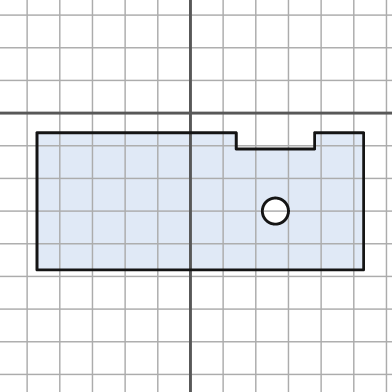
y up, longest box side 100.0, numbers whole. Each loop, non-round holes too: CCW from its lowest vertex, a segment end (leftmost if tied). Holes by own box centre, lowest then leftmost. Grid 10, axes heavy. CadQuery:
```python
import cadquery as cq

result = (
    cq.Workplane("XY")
    .moveTo(-47.0, -48.0)
    .lineTo(53.0, -48.0)
    .lineTo(53.0, -6.0)
    .lineTo(38.0, -6.0)
    .lineTo(38.0, -11.0)
    .lineTo(14.0, -11.0)
    .lineTo(14.0, -6.0)
    .lineTo(-47.0, -6.0)
    .close()
    .moveTo(26.0, -30.0)
    .circle(4.0)
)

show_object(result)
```